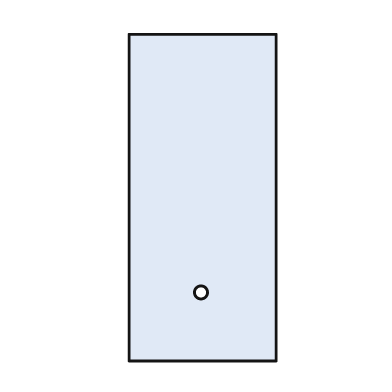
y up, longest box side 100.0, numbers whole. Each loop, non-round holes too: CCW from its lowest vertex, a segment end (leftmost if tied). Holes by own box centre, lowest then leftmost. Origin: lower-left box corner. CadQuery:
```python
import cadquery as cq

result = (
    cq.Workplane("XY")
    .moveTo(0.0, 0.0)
    .lineTo(45.0, 0.0)
    .lineTo(45.0, 100.0)
    .lineTo(0.0, 100.0)
    .close()
    .moveTo(22.0, 21.0)
    .circle(2.0)
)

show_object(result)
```